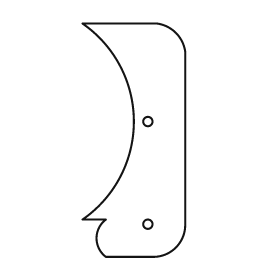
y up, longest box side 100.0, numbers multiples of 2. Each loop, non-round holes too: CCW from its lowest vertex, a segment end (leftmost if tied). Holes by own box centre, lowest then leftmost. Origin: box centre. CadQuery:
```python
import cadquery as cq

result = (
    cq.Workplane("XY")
    .moveTo(-12.0, -50.0)
    .lineTo(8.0, -50.0)
    .threePointArc((18.0, -46.0), (22.0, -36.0))
    .lineTo(22.0, 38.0)
    .threePointArc((18.0, 46.0), (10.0, 50.0))
    .lineTo(-22.0, 50.0)
    .threePointArc((0.0, 8.0), (-22.0, -34.0))
    .lineTo(-12.0, -34.0)
    .threePointArc((-16.0, -42.0), (-12.0, -50.0))
    .close()
    .moveTo(6.0, -36.0)
    .circle(2.0)
    .moveTo(6.0, 8.0)
    .circle(2.0)
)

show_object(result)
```